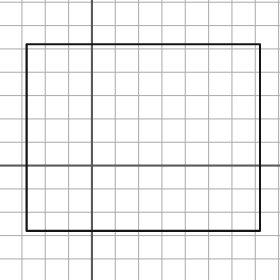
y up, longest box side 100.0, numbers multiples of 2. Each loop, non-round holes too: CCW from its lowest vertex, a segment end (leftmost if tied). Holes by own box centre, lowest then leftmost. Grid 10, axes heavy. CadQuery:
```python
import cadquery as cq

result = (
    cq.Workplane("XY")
    .moveTo(-28.0, -28.0)
    .lineTo(72.0, -28.0)
    .lineTo(72.0, 52.0)
    .lineTo(-28.0, 52.0)
    .close()
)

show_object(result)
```